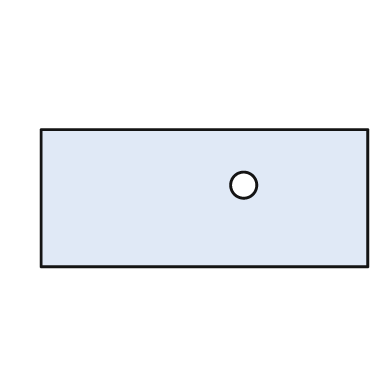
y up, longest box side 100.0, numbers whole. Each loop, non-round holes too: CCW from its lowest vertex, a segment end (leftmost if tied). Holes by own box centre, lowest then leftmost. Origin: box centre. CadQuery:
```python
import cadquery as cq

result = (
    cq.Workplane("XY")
    .moveTo(-50.0, -21.0)
    .lineTo(50.0, -21.0)
    .lineTo(50.0, 21.0)
    .lineTo(-50.0, 21.0)
    .close()
    .moveTo(12.0, 4.0)
    .circle(4.0)
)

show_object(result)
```